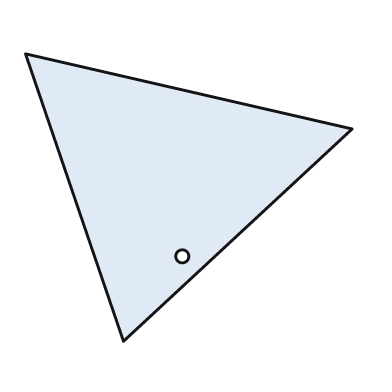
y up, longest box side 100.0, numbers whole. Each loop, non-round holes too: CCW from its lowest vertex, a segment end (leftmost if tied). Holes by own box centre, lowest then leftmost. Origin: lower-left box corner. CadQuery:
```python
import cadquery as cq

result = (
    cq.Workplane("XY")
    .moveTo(30.0, 0.0)
    .lineTo(100.0, 65.0)
    .lineTo(0.0, 88.0)
    .close()
    .moveTo(48.0, 26.0)
    .circle(2.0)
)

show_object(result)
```